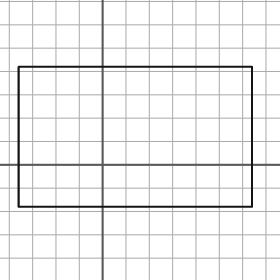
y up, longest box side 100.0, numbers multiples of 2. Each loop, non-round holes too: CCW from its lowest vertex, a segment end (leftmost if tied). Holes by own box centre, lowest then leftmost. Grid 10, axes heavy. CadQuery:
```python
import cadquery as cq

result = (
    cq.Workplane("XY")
    .moveTo(-36.0, -18.0)
    .lineTo(64.0, -18.0)
    .lineTo(64.0, 42.0)
    .lineTo(-36.0, 42.0)
    .close()
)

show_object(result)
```